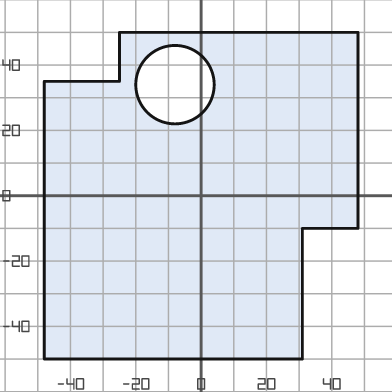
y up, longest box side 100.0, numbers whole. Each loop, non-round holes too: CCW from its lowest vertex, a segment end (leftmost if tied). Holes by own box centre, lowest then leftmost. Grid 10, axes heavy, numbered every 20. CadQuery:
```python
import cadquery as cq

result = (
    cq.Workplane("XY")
    .moveTo(-48.0, -50.0)
    .lineTo(31.0, -50.0)
    .lineTo(31.0, -10.0)
    .lineTo(48.0, -10.0)
    .lineTo(48.0, 50.0)
    .lineTo(-25.0, 50.0)
    .lineTo(-25.0, 35.0)
    .lineTo(-48.0, 35.0)
    .close()
    .moveTo(-8.0, 34.0)
    .circle(12.0)
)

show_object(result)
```